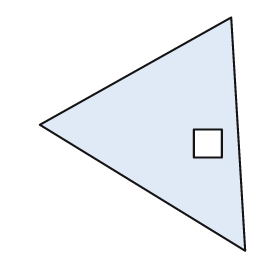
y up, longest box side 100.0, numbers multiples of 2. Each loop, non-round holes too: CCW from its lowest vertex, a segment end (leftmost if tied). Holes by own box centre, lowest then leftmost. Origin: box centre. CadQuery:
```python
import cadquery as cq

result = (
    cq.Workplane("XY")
    .moveTo(44.0, -50.0)
    .lineTo(38.0, 50.0)
    .lineTo(-44.0, 4.0)
    .close()
    .moveTo(22.0, -10.0)
    .lineTo(34.0, -10.0)
    .lineTo(34.0, 2.0)
    .lineTo(22.0, 2.0)
    .close()
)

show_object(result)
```